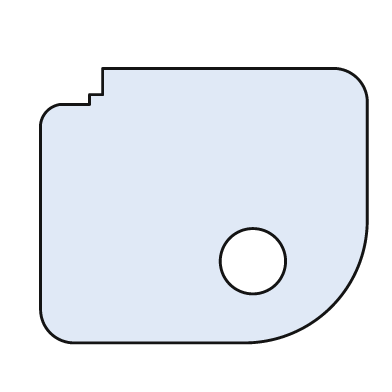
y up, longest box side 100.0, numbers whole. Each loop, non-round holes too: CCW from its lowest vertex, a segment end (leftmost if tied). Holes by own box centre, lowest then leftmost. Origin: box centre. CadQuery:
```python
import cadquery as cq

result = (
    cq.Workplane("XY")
    .moveTo(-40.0, -42.0)
    .lineTo(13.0, -42.0)
    .threePointArc((39.0, -31.0), (50.0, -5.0))
    .lineTo(50.0, 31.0)
    .threePointArc((47.0, 39.0), (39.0, 42.0))
    .lineTo(-31.0, 42.0)
    .lineTo(-31.0, 34.0)
    .lineTo(-35.0, 34.0)
    .lineTo(-35.0, 31.0)
    .lineTo(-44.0, 31.0)
    .threePointArc((-48.0, 29.0), (-50.0, 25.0))
    .lineTo(-50.0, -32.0)
    .threePointArc((-47.0, -39.0), (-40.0, -42.0))
    .close()
    .moveTo(15.0, -17.0)
    .circle(10.0)
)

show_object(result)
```